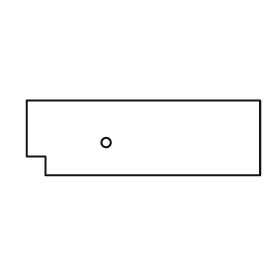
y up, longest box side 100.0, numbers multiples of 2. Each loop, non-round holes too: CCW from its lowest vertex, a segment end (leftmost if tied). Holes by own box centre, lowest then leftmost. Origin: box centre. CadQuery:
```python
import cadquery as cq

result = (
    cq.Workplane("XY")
    .moveTo(-42.0, -16.0)
    .lineTo(50.0, -16.0)
    .lineTo(50.0, 16.0)
    .lineTo(-50.0, 16.0)
    .lineTo(-50.0, -8.0)
    .lineTo(-42.0, -8.0)
    .close()
    .moveTo(-16.0, -2.0)
    .circle(2.0)
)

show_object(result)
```